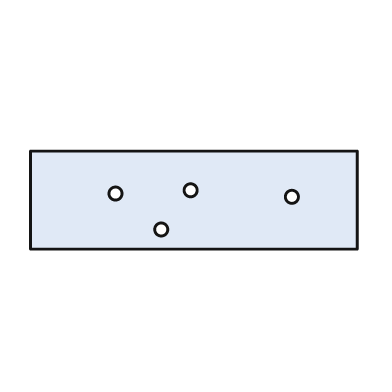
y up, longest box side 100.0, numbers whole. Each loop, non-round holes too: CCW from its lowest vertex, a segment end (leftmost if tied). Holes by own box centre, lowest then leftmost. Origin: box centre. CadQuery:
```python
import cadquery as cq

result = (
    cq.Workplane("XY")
    .moveTo(-50.0, -15.0)
    .lineTo(50.0, -15.0)
    .lineTo(50.0, 15.0)
    .lineTo(-50.0, 15.0)
    .close()
    .moveTo(-10.0, -9.0)
    .circle(2.0)
    .moveTo(30.0, 1.0)
    .circle(2.0)
    .moveTo(-24.0, 2.0)
    .circle(2.0)
    .moveTo(-1.0, 3.0)
    .circle(2.0)
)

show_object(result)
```